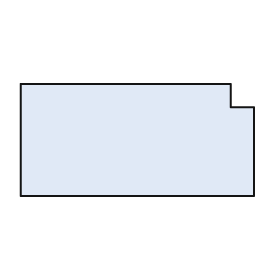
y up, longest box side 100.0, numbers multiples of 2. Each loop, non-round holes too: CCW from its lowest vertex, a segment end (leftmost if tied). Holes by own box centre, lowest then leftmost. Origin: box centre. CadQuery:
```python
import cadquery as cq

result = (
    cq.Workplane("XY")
    .moveTo(-50.0, -24.0)
    .lineTo(50.0, -24.0)
    .lineTo(50.0, 14.0)
    .lineTo(40.0, 14.0)
    .lineTo(40.0, 24.0)
    .lineTo(-50.0, 24.0)
    .close()
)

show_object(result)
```